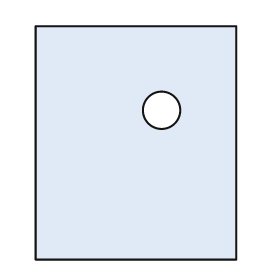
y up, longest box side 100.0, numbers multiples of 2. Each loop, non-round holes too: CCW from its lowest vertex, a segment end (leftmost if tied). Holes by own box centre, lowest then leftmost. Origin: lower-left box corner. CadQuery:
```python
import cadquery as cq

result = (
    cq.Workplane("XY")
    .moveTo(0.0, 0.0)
    .lineTo(86.0, 0.0)
    .lineTo(86.0, 100.0)
    .lineTo(0.0, 100.0)
    .close()
    .moveTo(54.0, 64.0)
    .circle(8.0)
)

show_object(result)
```